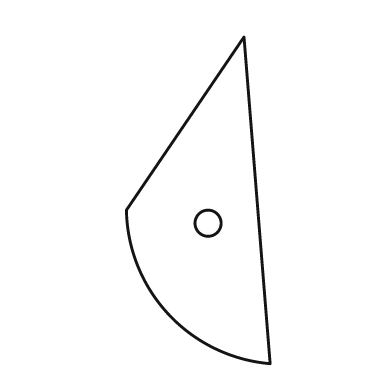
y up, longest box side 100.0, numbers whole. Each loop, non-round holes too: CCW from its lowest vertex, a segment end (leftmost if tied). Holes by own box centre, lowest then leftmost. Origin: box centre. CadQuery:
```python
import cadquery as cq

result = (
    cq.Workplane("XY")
    .moveTo(22.0, -50.0)
    .lineTo(14.0, 50.0)
    .lineTo(-22.0, -3.0)
    .threePointArc((-9.0, -35.0), (22.0, -50.0))
    .close()
    .moveTo(3.0, -7.0)
    .circle(4.0)
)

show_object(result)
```